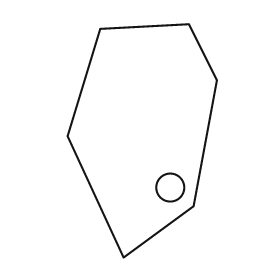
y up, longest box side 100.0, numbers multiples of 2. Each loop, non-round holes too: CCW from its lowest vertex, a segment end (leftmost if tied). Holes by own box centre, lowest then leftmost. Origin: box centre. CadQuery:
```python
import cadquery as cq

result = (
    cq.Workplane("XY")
    .moveTo(-8.0, -50.0)
    .lineTo(22.0, -28.0)
    .lineTo(32.0, 26.0)
    .lineTo(20.0, 50.0)
    .lineTo(-18.0, 48.0)
    .lineTo(-32.0, 2.0)
    .close()
    .moveTo(12.0, -20.0)
    .circle(6.0)
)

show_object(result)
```